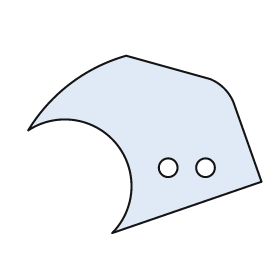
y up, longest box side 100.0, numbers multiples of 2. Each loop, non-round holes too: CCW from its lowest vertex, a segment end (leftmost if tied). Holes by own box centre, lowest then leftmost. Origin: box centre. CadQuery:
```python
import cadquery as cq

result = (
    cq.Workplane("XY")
    .moveTo(-14.0, -38.0)
    .lineTo(50.0, -16.0)
    .lineTo(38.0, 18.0)
    .threePointArc((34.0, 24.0), (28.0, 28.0))
    .lineTo(-8.0, 38.0)
    .threePointArc((-32.0, 26.0), (-50.0, 6.0))
    .threePointArc((-12.0, 0.0), (-14.0, -38.0))
    .close()
    .moveTo(10.0, -10.0)
    .circle(4.0)
    .moveTo(26.0, -10.0)
    .circle(4.0)
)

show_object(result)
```